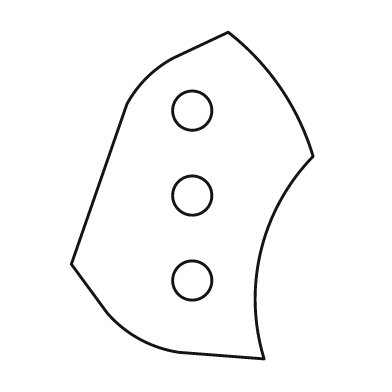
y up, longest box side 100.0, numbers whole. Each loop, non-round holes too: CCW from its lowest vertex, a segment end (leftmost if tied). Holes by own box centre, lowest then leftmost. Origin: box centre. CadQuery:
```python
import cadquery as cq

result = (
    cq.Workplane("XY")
    .moveTo(22.0, -50.0)
    .threePointArc((21.0, -17.0), (37.0, 12.0))
    .threePointArc((27.0, 33.0), (11.0, 50.0))
    .lineTo(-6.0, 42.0)
    .threePointArc((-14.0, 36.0), (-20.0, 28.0))
    .lineTo(-37.0, -21.0)
    .lineTo(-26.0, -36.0)
    .threePointArc((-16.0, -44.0), (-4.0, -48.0))
    .close()
    .moveTo(0.0, -26.0)
    .circle(6.0)
    .moveTo(0.0, 0.0)
    .circle(6.0)
    .moveTo(0.0, 26.0)
    .circle(6.0)
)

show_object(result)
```